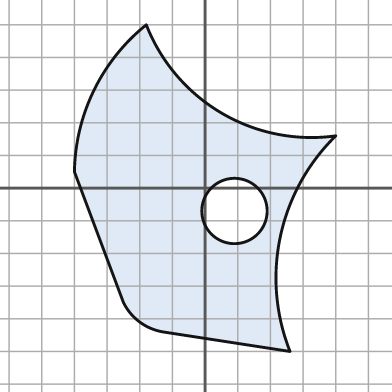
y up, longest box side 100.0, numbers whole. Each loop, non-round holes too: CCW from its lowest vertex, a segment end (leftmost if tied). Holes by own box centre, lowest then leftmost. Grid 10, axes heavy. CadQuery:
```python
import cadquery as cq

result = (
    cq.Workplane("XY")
    .moveTo(26.0, -50.0)
    .threePointArc((23.0, -15.0), (40.0, 16.0))
    .threePointArc((5.0, 23.0), (-18.0, 50.0))
    .threePointArc((-34.0, 30.0), (-40.0, 5.0))
    .lineTo(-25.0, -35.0)
    .threePointArc((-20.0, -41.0), (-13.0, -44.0))
    .close()
    .moveTo(9.0, -7.0)
    .circle(10.0)
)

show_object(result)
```